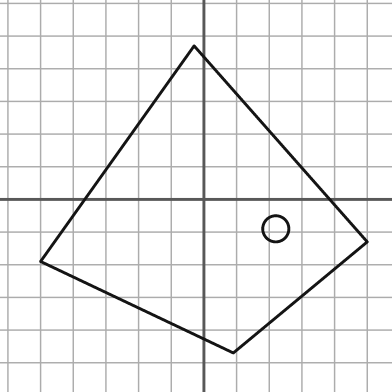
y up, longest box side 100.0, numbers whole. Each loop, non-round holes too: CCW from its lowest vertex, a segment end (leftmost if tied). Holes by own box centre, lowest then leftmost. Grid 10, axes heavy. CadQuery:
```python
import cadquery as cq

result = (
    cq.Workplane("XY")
    .moveTo(9.0, -47.0)
    .lineTo(50.0, -13.0)
    .lineTo(-3.0, 47.0)
    .lineTo(-50.0, -19.0)
    .close()
    .moveTo(22.0, -9.0)
    .circle(4.0)
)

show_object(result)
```